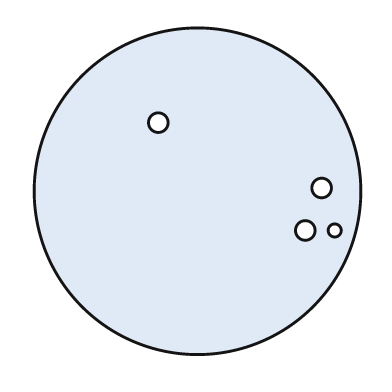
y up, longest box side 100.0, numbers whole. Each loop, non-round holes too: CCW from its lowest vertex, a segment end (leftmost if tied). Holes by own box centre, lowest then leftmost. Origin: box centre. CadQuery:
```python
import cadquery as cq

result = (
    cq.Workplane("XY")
    .moveTo(0.0, 0.0)
    .circle(50.0)
    .moveTo(33.0, -12.0)
    .circle(3.0)
    .moveTo(42.0, -12.0)
    .circle(2.0)
    .moveTo(38.0, 1.0)
    .circle(3.0)
    .moveTo(-12.0, 21.0)
    .circle(3.0)
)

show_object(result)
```